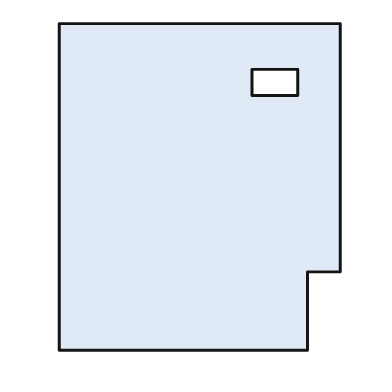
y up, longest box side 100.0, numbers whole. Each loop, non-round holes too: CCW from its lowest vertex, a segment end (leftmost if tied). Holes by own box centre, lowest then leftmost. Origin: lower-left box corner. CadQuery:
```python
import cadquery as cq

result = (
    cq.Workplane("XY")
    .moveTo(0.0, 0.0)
    .lineTo(76.0, 0.0)
    .lineTo(76.0, 24.0)
    .lineTo(86.0, 24.0)
    .lineTo(86.0, 100.0)
    .lineTo(0.0, 100.0)
    .close()
    .moveTo(59.0, 78.0)
    .lineTo(73.0, 78.0)
    .lineTo(73.0, 86.0)
    .lineTo(59.0, 86.0)
    .close()
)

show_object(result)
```